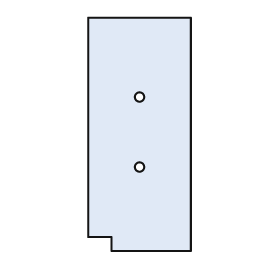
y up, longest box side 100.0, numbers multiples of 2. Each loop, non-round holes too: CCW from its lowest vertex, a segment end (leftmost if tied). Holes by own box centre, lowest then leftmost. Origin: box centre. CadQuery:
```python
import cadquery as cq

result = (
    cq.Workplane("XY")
    .moveTo(-12.0, -50.0)
    .lineTo(22.0, -50.0)
    .lineTo(22.0, 50.0)
    .lineTo(-22.0, 50.0)
    .lineTo(-22.0, -44.0)
    .lineTo(-12.0, -44.0)
    .close()
    .moveTo(0.0, -14.0)
    .circle(2.0)
    .moveTo(0.0, 16.0)
    .circle(2.0)
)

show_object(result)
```